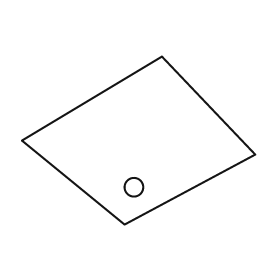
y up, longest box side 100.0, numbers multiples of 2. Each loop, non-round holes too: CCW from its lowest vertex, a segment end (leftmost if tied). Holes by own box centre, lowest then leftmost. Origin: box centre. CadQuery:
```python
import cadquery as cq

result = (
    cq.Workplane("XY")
    .moveTo(-6.0, -36.0)
    .lineTo(50.0, -6.0)
    .lineTo(10.0, 36.0)
    .lineTo(-50.0, 0.0)
    .close()
    .moveTo(-2.0, -20.0)
    .circle(4.0)
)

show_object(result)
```